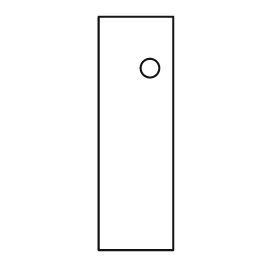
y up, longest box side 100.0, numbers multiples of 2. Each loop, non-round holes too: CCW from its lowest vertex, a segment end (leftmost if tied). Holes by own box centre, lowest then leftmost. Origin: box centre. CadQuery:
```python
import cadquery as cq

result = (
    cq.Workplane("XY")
    .moveTo(-16.0, -50.0)
    .lineTo(16.0, -50.0)
    .lineTo(16.0, 50.0)
    .lineTo(-16.0, 50.0)
    .close()
    .moveTo(6.0, 28.0)
    .circle(4.0)
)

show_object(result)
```